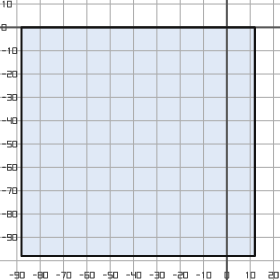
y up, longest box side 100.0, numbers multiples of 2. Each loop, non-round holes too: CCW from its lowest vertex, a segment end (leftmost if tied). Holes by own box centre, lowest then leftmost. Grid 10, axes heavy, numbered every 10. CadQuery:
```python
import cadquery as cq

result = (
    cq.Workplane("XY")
    .moveTo(-88.0, -98.0)
    .lineTo(12.0, -98.0)
    .lineTo(12.0, 0.0)
    .lineTo(-88.0, 0.0)
    .close()
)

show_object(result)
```